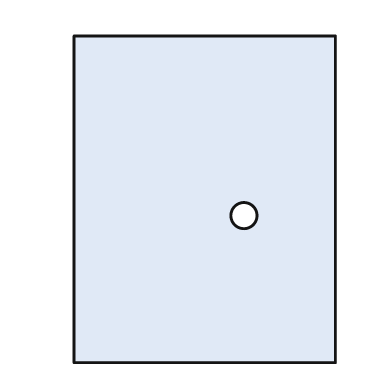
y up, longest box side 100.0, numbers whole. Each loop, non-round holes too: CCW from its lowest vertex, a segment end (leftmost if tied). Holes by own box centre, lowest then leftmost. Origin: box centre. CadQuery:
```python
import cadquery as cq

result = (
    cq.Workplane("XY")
    .moveTo(-40.0, -50.0)
    .lineTo(40.0, -50.0)
    .lineTo(40.0, 50.0)
    .lineTo(-40.0, 50.0)
    .close()
    .moveTo(12.0, -5.0)
    .circle(4.0)
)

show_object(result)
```